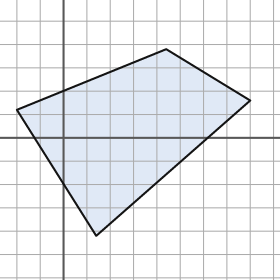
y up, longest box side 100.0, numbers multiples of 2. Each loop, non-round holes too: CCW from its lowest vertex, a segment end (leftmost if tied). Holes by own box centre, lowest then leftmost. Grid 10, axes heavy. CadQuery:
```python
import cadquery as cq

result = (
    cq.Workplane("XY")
    .moveTo(14.0, -42.0)
    .lineTo(80.0, 16.0)
    .lineTo(44.0, 38.0)
    .lineTo(-20.0, 12.0)
    .close()
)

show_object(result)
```